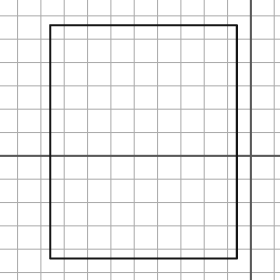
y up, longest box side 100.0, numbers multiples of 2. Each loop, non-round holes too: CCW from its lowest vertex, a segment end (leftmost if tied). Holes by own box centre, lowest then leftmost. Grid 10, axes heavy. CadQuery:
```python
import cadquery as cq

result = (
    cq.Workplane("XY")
    .moveTo(-86.0, -44.0)
    .lineTo(-6.0, -44.0)
    .lineTo(-6.0, 56.0)
    .lineTo(-86.0, 56.0)
    .close()
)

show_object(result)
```